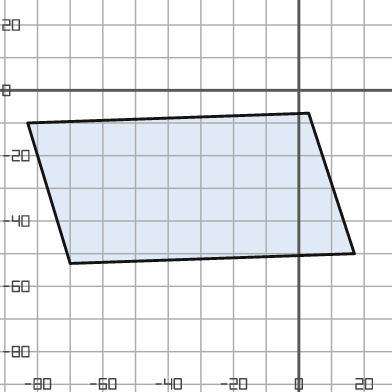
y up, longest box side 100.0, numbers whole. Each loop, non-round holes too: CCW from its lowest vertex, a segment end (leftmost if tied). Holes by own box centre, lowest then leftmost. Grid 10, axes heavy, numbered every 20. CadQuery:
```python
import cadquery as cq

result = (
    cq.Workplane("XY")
    .moveTo(-70.0, -53.0)
    .lineTo(17.0, -50.0)
    .lineTo(3.0, -7.0)
    .lineTo(-83.0, -10.0)
    .close()
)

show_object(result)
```